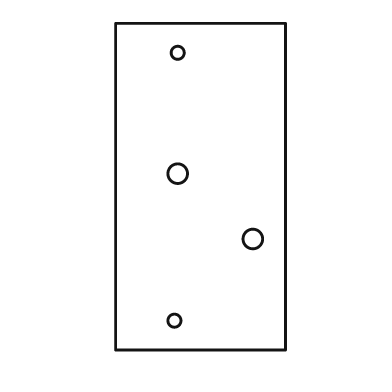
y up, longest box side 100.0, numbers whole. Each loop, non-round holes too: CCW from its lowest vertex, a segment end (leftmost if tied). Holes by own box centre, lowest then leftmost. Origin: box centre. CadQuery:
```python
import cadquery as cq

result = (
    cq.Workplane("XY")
    .moveTo(-26.0, -50.0)
    .lineTo(26.0, -50.0)
    .lineTo(26.0, 50.0)
    .lineTo(-26.0, 50.0)
    .close()
    .moveTo(-8.0, -41.0)
    .circle(2.0)
    .moveTo(16.0, -16.0)
    .circle(3.0)
    .moveTo(-7.0, 4.0)
    .circle(3.0)
    .moveTo(-7.0, 41.0)
    .circle(2.0)
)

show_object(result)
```